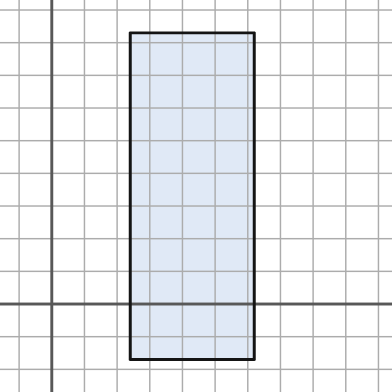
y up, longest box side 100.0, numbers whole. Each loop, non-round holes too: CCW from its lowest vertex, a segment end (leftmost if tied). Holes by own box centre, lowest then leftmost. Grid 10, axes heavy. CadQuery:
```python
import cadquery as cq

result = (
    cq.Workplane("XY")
    .moveTo(24.0, -17.0)
    .lineTo(62.0, -17.0)
    .lineTo(62.0, 83.0)
    .lineTo(24.0, 83.0)
    .close()
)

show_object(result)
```